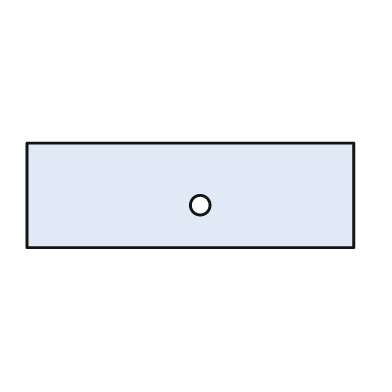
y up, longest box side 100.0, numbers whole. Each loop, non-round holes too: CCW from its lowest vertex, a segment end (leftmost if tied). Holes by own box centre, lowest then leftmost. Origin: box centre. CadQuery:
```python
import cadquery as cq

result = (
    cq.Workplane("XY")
    .moveTo(-50.0, -16.0)
    .lineTo(50.0, -16.0)
    .lineTo(50.0, 16.0)
    .lineTo(-50.0, 16.0)
    .close()
    .moveTo(3.0, -3.0)
    .circle(3.0)
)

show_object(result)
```